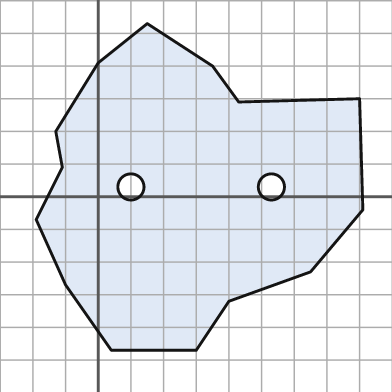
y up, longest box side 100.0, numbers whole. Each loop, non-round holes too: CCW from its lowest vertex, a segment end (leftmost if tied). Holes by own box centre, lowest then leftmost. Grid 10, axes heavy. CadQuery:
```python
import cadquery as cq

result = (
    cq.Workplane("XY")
    .moveTo(4.0, -47.0)
    .lineTo(30.0, -47.0)
    .lineTo(40.0, -32.0)
    .lineTo(65.0, -23.0)
    .lineTo(81.0, -4.0)
    .lineTo(80.0, 30.0)
    .lineTo(43.0, 29.0)
    .lineTo(35.0, 40.0)
    .lineTo(15.0, 53.0)
    .lineTo(0.0, 41.0)
    .lineTo(-13.0, 20.0)
    .lineTo(-11.0, 9.0)
    .lineTo(-19.0, -7.0)
    .lineTo(-10.0, -27.0)
    .close()
    .moveTo(10.0, 3.0)
    .circle(4.0)
    .moveTo(53.0, 3.0)
    .circle(4.0)
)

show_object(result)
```